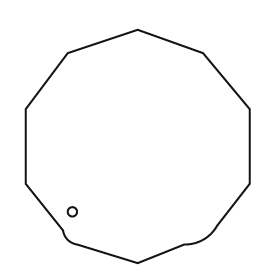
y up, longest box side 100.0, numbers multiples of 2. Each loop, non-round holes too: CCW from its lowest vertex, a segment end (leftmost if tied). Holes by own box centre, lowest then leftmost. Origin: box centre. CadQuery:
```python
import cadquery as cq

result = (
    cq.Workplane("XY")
    .moveTo(0.0, -50.0)
    .lineTo(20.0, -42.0)
    .threePointArc((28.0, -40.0), (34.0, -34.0))
    .lineTo(48.0, -16.0)
    .lineTo(48.0, 16.0)
    .lineTo(28.0, 40.0)
    .lineTo(0.0, 50.0)
    .lineTo(-30.0, 40.0)
    .lineTo(-48.0, 16.0)
    .lineTo(-48.0, -16.0)
    .lineTo(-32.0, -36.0)
    .threePointArc((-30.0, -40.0), (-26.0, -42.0))
    .close()
    .moveTo(-28.0, -28.0)
    .circle(2.0)
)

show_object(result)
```